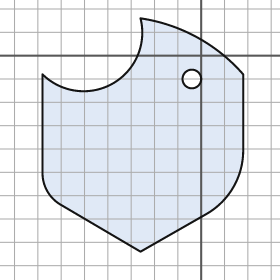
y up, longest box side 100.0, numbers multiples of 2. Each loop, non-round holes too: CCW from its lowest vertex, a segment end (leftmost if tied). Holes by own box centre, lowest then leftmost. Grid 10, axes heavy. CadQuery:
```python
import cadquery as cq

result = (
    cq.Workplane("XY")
    .moveTo(-26.0, -84.0)
    .lineTo(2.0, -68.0)
    .threePointArc((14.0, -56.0), (18.0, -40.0))
    .lineTo(18.0, -8.0)
    .threePointArc((-2.0, 8.0), (-26.0, 16.0))
    .threePointArc((-38.0, -12.0), (-68.0, -8.0))
    .lineTo(-68.0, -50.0)
    .threePointArc((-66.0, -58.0), (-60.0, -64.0))
    .close()
    .moveTo(-4.0, -10.0)
    .circle(4.0)
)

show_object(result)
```